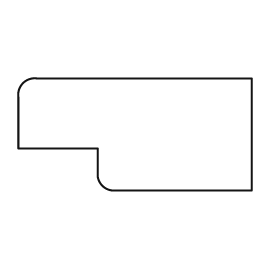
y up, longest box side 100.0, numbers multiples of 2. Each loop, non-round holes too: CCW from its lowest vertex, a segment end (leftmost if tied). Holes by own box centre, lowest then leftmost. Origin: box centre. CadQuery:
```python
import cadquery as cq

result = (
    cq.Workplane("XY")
    .moveTo(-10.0, -24.0)
    .lineTo(50.0, -24.0)
    .lineTo(50.0, 24.0)
    .lineTo(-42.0, 24.0)
    .threePointArc((-48.0, 22.0), (-50.0, 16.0))
    .lineTo(-50.0, -6.0)
    .lineTo(-16.0, -6.0)
    .lineTo(-16.0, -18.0)
    .threePointArc((-14.0, -22.0), (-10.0, -24.0))
    .close()
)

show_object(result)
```